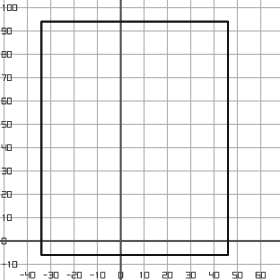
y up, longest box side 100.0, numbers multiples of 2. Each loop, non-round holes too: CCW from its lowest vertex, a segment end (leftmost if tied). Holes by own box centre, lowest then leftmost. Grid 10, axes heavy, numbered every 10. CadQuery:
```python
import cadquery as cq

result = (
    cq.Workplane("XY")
    .moveTo(-34.0, -6.0)
    .lineTo(46.0, -6.0)
    .lineTo(46.0, 94.0)
    .lineTo(-34.0, 94.0)
    .close()
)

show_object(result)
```